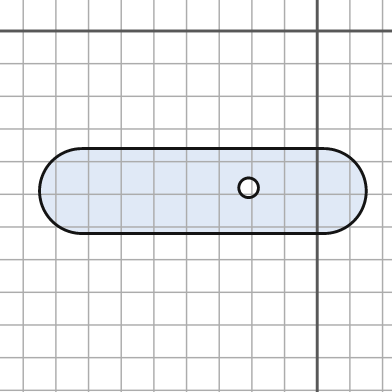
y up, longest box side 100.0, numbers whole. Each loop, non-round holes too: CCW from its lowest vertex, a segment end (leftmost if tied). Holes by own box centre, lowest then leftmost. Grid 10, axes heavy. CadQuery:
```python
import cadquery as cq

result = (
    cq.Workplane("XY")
    .moveTo(-72.0, -62.0)
    .lineTo(2.0, -62.0)
    .threePointArc((15.0, -49.0), (2.0, -36.0))
    .lineTo(-72.0, -36.0)
    .threePointArc((-85.0, -49.0), (-72.0, -62.0))
    .close()
    .moveTo(-21.0, -48.0)
    .circle(3.0)
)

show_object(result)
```